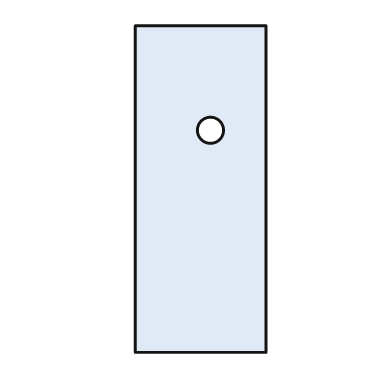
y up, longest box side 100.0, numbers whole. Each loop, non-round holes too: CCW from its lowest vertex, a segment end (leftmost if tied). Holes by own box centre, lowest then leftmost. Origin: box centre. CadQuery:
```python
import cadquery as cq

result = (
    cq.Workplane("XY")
    .moveTo(-20.0, -50.0)
    .lineTo(20.0, -50.0)
    .lineTo(20.0, 50.0)
    .lineTo(-20.0, 50.0)
    .close()
    .moveTo(3.0, 18.0)
    .circle(4.0)
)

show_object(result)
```